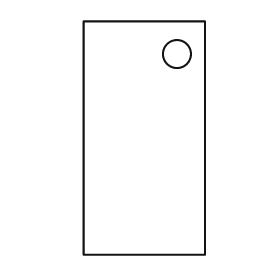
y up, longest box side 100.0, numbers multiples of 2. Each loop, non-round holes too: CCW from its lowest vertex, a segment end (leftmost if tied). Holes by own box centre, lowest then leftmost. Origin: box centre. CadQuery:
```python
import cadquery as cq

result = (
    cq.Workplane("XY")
    .moveTo(-26.0, -50.0)
    .lineTo(26.0, -50.0)
    .lineTo(26.0, 50.0)
    .lineTo(-26.0, 50.0)
    .close()
    .moveTo(14.0, 36.0)
    .circle(6.0)
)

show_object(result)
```